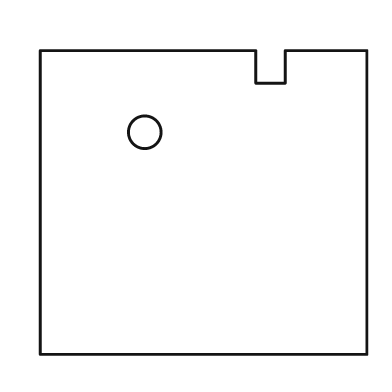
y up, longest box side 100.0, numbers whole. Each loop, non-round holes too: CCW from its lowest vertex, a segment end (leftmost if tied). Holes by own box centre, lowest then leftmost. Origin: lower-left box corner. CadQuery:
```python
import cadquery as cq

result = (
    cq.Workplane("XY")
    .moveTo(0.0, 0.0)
    .lineTo(100.0, 0.0)
    .lineTo(100.0, 93.0)
    .lineTo(75.0, 93.0)
    .lineTo(75.0, 83.0)
    .lineTo(66.0, 83.0)
    .lineTo(66.0, 93.0)
    .lineTo(0.0, 93.0)
    .close()
    .moveTo(32.0, 68.0)
    .circle(5.0)
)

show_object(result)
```